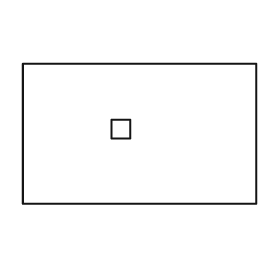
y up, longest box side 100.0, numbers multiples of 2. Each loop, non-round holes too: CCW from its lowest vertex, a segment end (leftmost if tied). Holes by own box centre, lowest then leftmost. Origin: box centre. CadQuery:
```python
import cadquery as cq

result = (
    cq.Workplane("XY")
    .moveTo(-50.0, -30.0)
    .lineTo(50.0, -30.0)
    .lineTo(50.0, 30.0)
    .lineTo(-50.0, 30.0)
    .close()
    .moveTo(-12.0, -2.0)
    .lineTo(-4.0, -2.0)
    .lineTo(-4.0, 6.0)
    .lineTo(-12.0, 6.0)
    .close()
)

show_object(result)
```